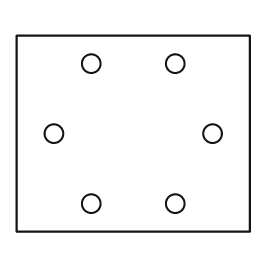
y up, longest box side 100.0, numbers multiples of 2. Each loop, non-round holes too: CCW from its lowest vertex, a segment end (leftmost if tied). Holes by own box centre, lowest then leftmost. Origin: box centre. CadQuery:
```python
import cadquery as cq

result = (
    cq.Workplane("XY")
    .moveTo(-50.0, -42.0)
    .lineTo(50.0, -42.0)
    .lineTo(50.0, 42.0)
    .lineTo(-50.0, 42.0)
    .close()
    .moveTo(-18.0, -30.0)
    .circle(4.0)
    .moveTo(18.0, -30.0)
    .circle(4.0)
    .moveTo(-34.0, 0.0)
    .circle(4.0)
    .moveTo(34.0, 0.0)
    .circle(4.0)
    .moveTo(-18.0, 30.0)
    .circle(4.0)
    .moveTo(18.0, 30.0)
    .circle(4.0)
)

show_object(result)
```